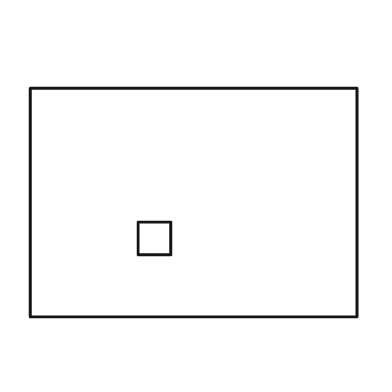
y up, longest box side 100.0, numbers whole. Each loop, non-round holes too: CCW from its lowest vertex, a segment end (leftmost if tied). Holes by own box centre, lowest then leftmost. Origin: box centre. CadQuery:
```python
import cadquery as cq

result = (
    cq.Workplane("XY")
    .moveTo(-50.0, -35.0)
    .lineTo(50.0, -35.0)
    .lineTo(50.0, 35.0)
    .lineTo(-50.0, 35.0)
    .close()
    .moveTo(-17.0, -16.0)
    .lineTo(-7.0, -16.0)
    .lineTo(-7.0, -6.0)
    .lineTo(-17.0, -6.0)
    .close()
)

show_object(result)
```